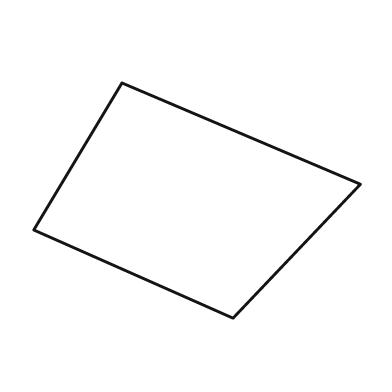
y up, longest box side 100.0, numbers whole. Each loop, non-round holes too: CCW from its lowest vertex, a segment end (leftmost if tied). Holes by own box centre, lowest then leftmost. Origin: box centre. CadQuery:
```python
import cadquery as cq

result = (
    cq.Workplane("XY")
    .moveTo(11.0, -36.0)
    .lineTo(50.0, 5.0)
    .lineTo(-23.0, 36.0)
    .lineTo(-50.0, -9.0)
    .close()
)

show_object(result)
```